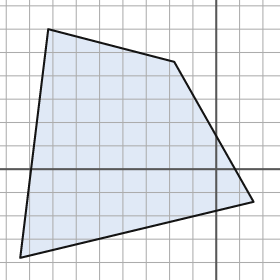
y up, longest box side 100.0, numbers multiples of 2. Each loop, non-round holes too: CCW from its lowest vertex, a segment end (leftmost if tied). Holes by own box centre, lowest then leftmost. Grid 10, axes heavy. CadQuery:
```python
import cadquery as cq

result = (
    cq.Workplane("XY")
    .moveTo(-84.0, -38.0)
    .lineTo(16.0, -14.0)
    .lineTo(-18.0, 46.0)
    .lineTo(-72.0, 60.0)
    .close()
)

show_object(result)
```